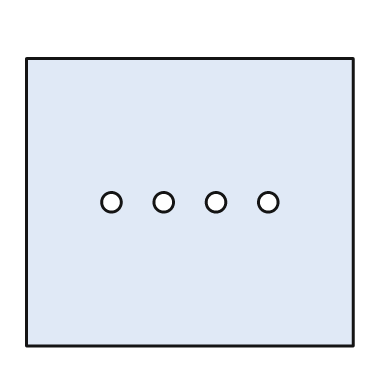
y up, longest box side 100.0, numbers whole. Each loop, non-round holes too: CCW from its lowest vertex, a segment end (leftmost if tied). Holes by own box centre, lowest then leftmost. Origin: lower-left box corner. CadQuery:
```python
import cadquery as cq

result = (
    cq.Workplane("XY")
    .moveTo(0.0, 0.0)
    .lineTo(100.0, 0.0)
    .lineTo(100.0, 88.0)
    .lineTo(0.0, 88.0)
    .close()
    .moveTo(26.0, 44.0)
    .circle(3.0)
    .moveTo(42.0, 44.0)
    .circle(3.0)
    .moveTo(58.0, 44.0)
    .circle(3.0)
    .moveTo(74.0, 44.0)
    .circle(3.0)
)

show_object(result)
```